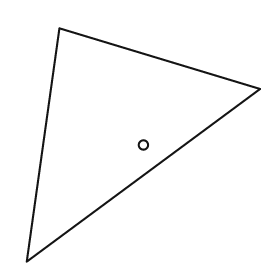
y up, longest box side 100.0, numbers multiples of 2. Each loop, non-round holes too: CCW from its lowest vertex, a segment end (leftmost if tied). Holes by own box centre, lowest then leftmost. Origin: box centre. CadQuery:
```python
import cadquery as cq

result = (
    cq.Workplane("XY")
    .moveTo(-50.0, -50.0)
    .lineTo(50.0, 24.0)
    .lineTo(-36.0, 50.0)
    .close()
    .moveTo(0.0, 0.0)
    .circle(2.0)
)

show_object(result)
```